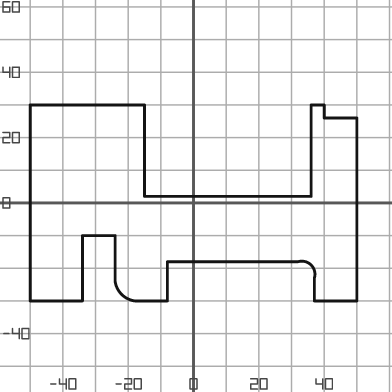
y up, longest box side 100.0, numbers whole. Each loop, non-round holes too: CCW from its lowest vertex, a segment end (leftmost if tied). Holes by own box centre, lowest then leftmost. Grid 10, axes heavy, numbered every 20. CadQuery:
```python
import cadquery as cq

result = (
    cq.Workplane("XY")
    .moveTo(-50.0, -30.0)
    .lineTo(-34.0, -30.0)
    .lineTo(-34.0, -10.0)
    .lineTo(-24.0, -10.0)
    .lineTo(-24.0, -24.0)
    .threePointArc((-22.0, -28.0), (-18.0, -30.0))
    .lineTo(-8.0, -30.0)
    .lineTo(-8.0, -18.0)
    .lineTo(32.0, -18.0)
    .threePointArc((36.0, -19.0), (37.0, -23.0))
    .lineTo(37.0, -30.0)
    .lineTo(50.0, -30.0)
    .lineTo(50.0, 26.0)
    .lineTo(40.0, 26.0)
    .lineTo(40.0, 30.0)
    .lineTo(36.0, 30.0)
    .lineTo(36.0, 2.0)
    .lineTo(-15.0, 2.0)
    .lineTo(-15.0, 30.0)
    .lineTo(-50.0, 30.0)
    .close()
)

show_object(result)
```